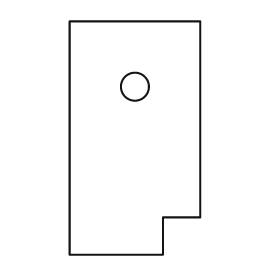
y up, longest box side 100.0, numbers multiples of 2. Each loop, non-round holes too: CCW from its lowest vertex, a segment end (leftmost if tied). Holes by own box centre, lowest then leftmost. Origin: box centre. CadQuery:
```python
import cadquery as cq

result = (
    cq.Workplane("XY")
    .moveTo(-28.0, -50.0)
    .lineTo(12.0, -50.0)
    .lineTo(12.0, -34.0)
    .lineTo(28.0, -34.0)
    .lineTo(28.0, 50.0)
    .lineTo(-28.0, 50.0)
    .close()
    .moveTo(0.0, 22.0)
    .circle(6.0)
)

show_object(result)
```